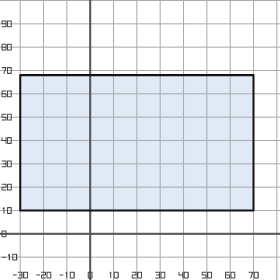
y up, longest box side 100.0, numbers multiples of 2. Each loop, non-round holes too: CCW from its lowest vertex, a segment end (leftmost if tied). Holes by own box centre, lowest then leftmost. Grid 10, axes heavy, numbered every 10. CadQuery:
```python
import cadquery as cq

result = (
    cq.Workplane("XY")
    .moveTo(-30.0, 10.0)
    .lineTo(70.0, 10.0)
    .lineTo(70.0, 68.0)
    .lineTo(-30.0, 68.0)
    .close()
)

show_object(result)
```